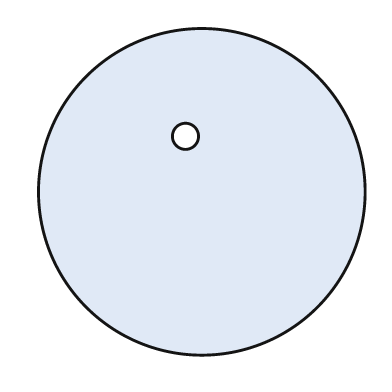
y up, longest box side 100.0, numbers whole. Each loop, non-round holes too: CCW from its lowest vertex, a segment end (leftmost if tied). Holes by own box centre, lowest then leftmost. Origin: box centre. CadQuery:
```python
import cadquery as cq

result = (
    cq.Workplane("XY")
    .moveTo(0.0, 0.0)
    .circle(50.0)
    .moveTo(-5.0, 17.0)
    .circle(4.0)
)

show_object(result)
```